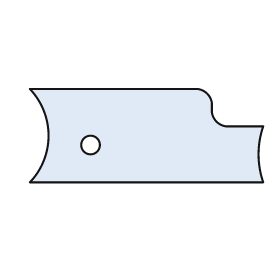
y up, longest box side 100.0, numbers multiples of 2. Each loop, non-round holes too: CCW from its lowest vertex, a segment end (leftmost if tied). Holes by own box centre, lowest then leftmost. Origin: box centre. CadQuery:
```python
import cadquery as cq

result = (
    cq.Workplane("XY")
    .moveTo(-50.0, -20.0)
    .lineTo(50.0, -20.0)
    .threePointArc((48.0, -8.0), (50.0, 4.0))
    .lineTo(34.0, 4.0)
    .threePointArc((30.0, 6.0), (28.0, 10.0))
    .lineTo(28.0, 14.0)
    .threePointArc((26.0, 18.0), (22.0, 20.0))
    .lineTo(-50.0, 20.0)
    .threePointArc((-42.0, 0.0), (-50.0, -20.0))
    .close()
    .moveTo(-24.0, -4.0)
    .circle(4.0)
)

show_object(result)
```